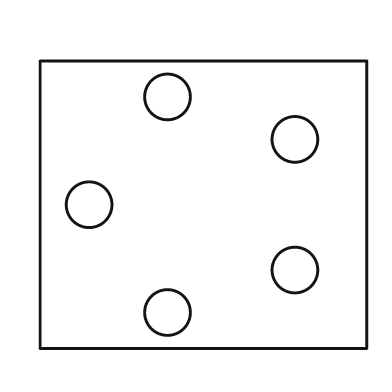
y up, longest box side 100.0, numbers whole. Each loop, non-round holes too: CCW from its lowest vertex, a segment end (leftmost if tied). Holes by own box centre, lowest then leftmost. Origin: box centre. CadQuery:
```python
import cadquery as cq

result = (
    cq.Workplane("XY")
    .moveTo(-50.0, -44.0)
    .lineTo(50.0, -44.0)
    .lineTo(50.0, 44.0)
    .lineTo(-50.0, 44.0)
    .close()
    .moveTo(-11.0, -33.0)
    .circle(7.0)
    .moveTo(28.0, -20.0)
    .circle(7.0)
    .moveTo(-35.0, 0.0)
    .circle(7.0)
    .moveTo(28.0, 20.0)
    .circle(7.0)
    .moveTo(-11.0, 33.0)
    .circle(7.0)
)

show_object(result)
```